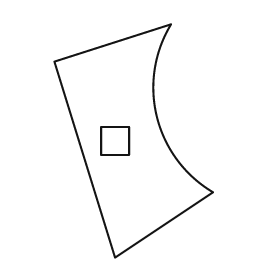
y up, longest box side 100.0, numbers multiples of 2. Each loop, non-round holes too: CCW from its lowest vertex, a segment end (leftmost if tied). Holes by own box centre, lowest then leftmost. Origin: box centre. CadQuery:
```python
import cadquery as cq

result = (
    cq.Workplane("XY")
    .moveTo(-8.0, -50.0)
    .lineTo(34.0, -22.0)
    .threePointArc((10.0, 10.0), (16.0, 50.0))
    .lineTo(-34.0, 34.0)
    .close()
    .moveTo(-14.0, -6.0)
    .lineTo(-2.0, -6.0)
    .lineTo(-2.0, 6.0)
    .lineTo(-14.0, 6.0)
    .close()
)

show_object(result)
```